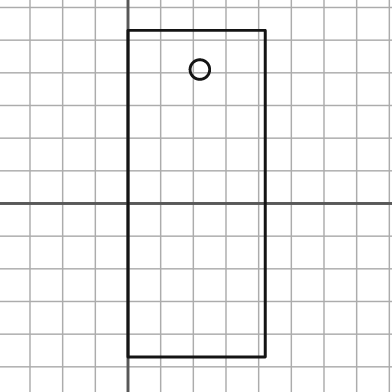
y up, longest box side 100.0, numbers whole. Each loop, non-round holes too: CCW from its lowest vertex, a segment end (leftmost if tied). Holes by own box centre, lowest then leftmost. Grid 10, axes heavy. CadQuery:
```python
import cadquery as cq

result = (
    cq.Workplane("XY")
    .moveTo(0.0, -47.0)
    .lineTo(42.0, -47.0)
    .lineTo(42.0, 53.0)
    .lineTo(0.0, 53.0)
    .close()
    .moveTo(22.0, 41.0)
    .circle(3.0)
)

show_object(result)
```